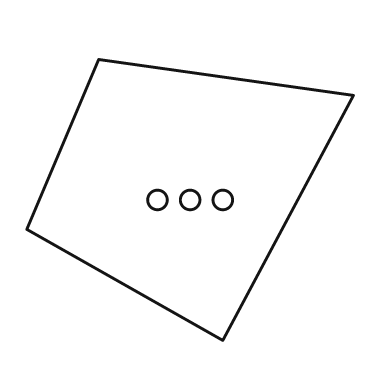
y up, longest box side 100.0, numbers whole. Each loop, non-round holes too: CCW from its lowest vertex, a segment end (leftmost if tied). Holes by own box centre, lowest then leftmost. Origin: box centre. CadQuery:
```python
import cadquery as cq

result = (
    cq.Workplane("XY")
    .moveTo(10.0, -43.0)
    .lineTo(50.0, 32.0)
    .lineTo(-28.0, 43.0)
    .lineTo(-50.0, -9.0)
    .close()
    .moveTo(-10.0, 0.0)
    .circle(3.0)
    .moveTo(0.0, 0.0)
    .circle(3.0)
    .moveTo(10.0, 0.0)
    .circle(3.0)
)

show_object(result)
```